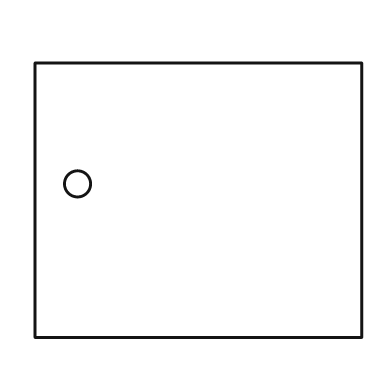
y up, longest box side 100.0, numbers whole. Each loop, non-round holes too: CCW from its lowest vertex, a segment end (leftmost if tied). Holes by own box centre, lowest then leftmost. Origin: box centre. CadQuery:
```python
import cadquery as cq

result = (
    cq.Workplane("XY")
    .moveTo(-50.0, -42.0)
    .lineTo(50.0, -42.0)
    .lineTo(50.0, 42.0)
    .lineTo(-50.0, 42.0)
    .close()
    .moveTo(-37.0, 5.0)
    .circle(4.0)
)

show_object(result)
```